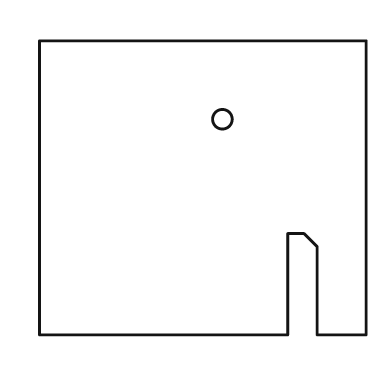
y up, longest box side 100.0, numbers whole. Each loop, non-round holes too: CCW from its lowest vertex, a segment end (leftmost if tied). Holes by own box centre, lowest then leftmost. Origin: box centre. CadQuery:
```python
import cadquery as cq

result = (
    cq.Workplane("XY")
    .moveTo(-50.0, -45.0)
    .lineTo(26.0, -45.0)
    .lineTo(26.0, -14.0)
    .lineTo(31.0, -14.0)
    .lineTo(35.0, -18.0)
    .lineTo(35.0, -45.0)
    .lineTo(50.0, -45.0)
    .lineTo(50.0, 45.0)
    .lineTo(-50.0, 45.0)
    .close()
    .moveTo(6.0, 21.0)
    .circle(3.0)
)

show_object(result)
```